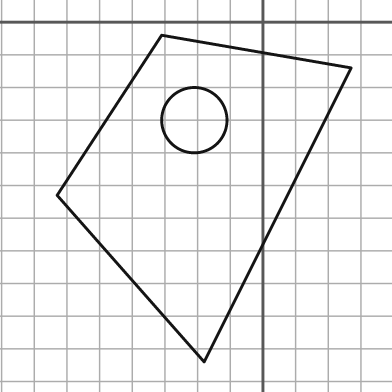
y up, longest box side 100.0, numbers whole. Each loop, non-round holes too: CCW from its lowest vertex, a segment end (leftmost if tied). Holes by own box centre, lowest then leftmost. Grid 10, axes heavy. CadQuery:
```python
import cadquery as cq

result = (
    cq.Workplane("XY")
    .moveTo(-18.0, -104.0)
    .lineTo(27.0, -14.0)
    .lineTo(-31.0, -4.0)
    .lineTo(-63.0, -53.0)
    .close()
    .moveTo(-21.0, -30.0)
    .circle(10.0)
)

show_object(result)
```